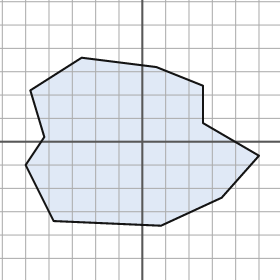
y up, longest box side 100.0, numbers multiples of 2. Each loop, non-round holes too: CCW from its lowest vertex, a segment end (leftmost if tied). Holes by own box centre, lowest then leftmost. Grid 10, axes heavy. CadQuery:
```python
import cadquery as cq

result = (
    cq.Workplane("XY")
    .moveTo(8.0, -36.0)
    .lineTo(34.0, -24.0)
    .lineTo(50.0, -6.0)
    .lineTo(26.0, 8.0)
    .lineTo(26.0, 24.0)
    .lineTo(6.0, 32.0)
    .lineTo(-26.0, 36.0)
    .lineTo(-48.0, 22.0)
    .lineTo(-42.0, 2.0)
    .lineTo(-50.0, -10.0)
    .lineTo(-38.0, -34.0)
    .close()
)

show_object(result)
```